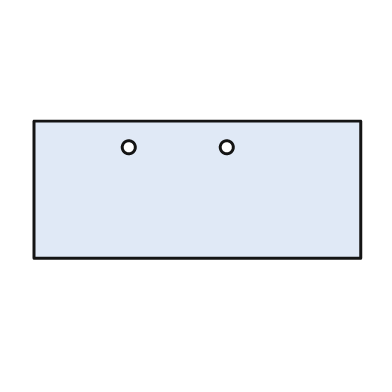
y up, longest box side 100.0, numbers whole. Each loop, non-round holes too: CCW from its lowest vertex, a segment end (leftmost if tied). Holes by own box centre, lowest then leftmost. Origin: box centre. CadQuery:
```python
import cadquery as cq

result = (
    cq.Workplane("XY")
    .moveTo(-50.0, -21.0)
    .lineTo(50.0, -21.0)
    .lineTo(50.0, 21.0)
    .lineTo(-50.0, 21.0)
    .close()
    .moveTo(-21.0, 13.0)
    .circle(2.0)
    .moveTo(9.0, 13.0)
    .circle(2.0)
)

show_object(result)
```